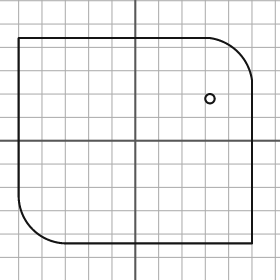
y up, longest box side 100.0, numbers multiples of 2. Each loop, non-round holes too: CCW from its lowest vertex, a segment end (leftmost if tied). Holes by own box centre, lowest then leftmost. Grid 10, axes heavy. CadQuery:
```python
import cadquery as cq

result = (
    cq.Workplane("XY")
    .moveTo(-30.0, -44.0)
    .lineTo(50.0, -44.0)
    .lineTo(50.0, 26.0)
    .threePointArc((44.0, 38.0), (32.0, 44.0))
    .lineTo(-50.0, 44.0)
    .lineTo(-50.0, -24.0)
    .threePointArc((-44.0, -38.0), (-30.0, -44.0))
    .close()
    .moveTo(32.0, 18.0)
    .circle(2.0)
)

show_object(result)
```